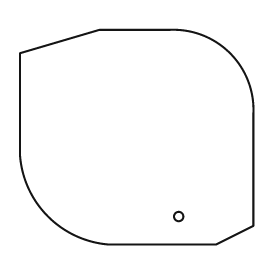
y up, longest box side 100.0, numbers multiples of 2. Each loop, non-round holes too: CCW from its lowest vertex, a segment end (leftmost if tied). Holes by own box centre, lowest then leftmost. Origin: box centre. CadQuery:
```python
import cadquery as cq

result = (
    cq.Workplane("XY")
    .moveTo(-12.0, -46.0)
    .lineTo(34.0, -46.0)
    .lineTo(50.0, -38.0)
    .lineTo(50.0, 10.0)
    .threePointArc((40.0, 36.0), (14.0, 46.0))
    .lineTo(-16.0, 46.0)
    .lineTo(-50.0, 36.0)
    .lineTo(-50.0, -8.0)
    .threePointArc((-38.0, -34.0), (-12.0, -46.0))
    .close()
    .moveTo(18.0, -34.0)
    .circle(2.0)
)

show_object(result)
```